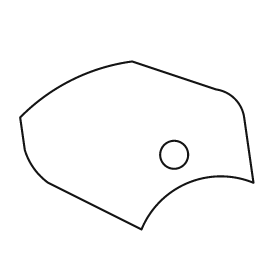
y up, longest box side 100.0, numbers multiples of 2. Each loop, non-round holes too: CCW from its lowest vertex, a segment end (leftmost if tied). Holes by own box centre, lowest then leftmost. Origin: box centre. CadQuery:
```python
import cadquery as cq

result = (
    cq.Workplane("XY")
    .moveTo(2.0, -36.0)
    .threePointArc((22.0, -16.0), (50.0, -16.0))
    .lineTo(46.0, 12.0)
    .threePointArc((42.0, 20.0), (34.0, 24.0))
    .lineTo(-2.0, 36.0)
    .threePointArc((-28.0, 28.0), (-50.0, 12.0))
    .lineTo(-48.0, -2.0)
    .threePointArc((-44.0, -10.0), (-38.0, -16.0))
    .close()
    .moveTo(16.0, -4.0)
    .circle(6.0)
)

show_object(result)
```